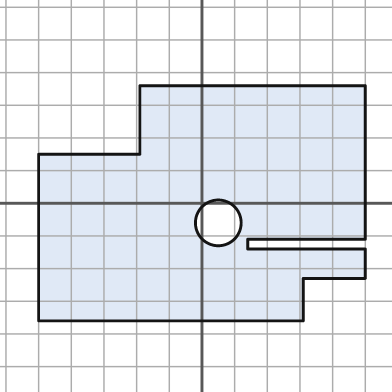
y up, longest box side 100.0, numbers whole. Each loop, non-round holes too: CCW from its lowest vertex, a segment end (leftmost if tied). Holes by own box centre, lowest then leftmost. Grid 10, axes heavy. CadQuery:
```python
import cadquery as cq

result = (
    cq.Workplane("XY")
    .moveTo(-50.0, -36.0)
    .lineTo(31.0, -36.0)
    .lineTo(31.0, -23.0)
    .lineTo(50.0, -23.0)
    .lineTo(50.0, -14.0)
    .lineTo(14.0, -14.0)
    .lineTo(14.0, -11.0)
    .lineTo(50.0, -11.0)
    .lineTo(50.0, 36.0)
    .lineTo(-19.0, 36.0)
    .lineTo(-19.0, 15.0)
    .lineTo(-50.0, 15.0)
    .close()
    .moveTo(5.0, -6.0)
    .circle(7.0)
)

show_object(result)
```